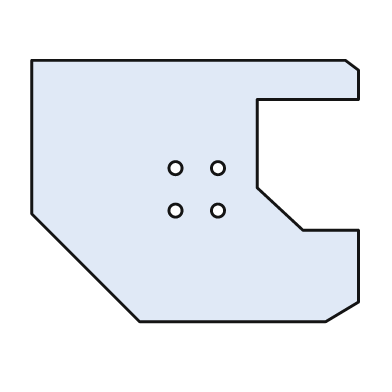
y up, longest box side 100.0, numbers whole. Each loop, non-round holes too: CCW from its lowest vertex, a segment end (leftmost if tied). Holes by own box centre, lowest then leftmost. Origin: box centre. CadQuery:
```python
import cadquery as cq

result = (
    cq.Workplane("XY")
    .moveTo(-17.0, -40.0)
    .lineTo(40.0, -40.0)
    .lineTo(50.0, -34.0)
    .lineTo(50.0, -12.0)
    .lineTo(33.0, -12.0)
    .lineTo(19.0, 1.0)
    .lineTo(19.0, 28.0)
    .lineTo(50.0, 28.0)
    .lineTo(50.0, 37.0)
    .lineTo(46.0, 40.0)
    .lineTo(-50.0, 40.0)
    .lineTo(-50.0, -7.0)
    .close()
    .moveTo(-6.0, -6.0)
    .circle(2.0)
    .moveTo(7.0, -6.0)
    .circle(2.0)
    .moveTo(-6.0, 7.0)
    .circle(2.0)
    .moveTo(7.0, 7.0)
    .circle(2.0)
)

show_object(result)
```